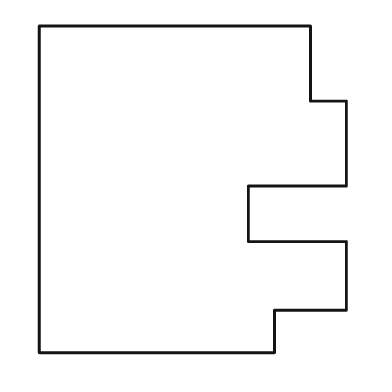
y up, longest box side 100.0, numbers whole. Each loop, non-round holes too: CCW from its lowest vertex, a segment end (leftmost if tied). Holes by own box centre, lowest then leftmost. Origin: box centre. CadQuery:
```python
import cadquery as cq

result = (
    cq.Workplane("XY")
    .moveTo(-47.0, -50.0)
    .lineTo(25.0, -50.0)
    .lineTo(25.0, -37.0)
    .lineTo(47.0, -37.0)
    .lineTo(47.0, -16.0)
    .lineTo(17.0, -16.0)
    .lineTo(17.0, 1.0)
    .lineTo(47.0, 1.0)
    .lineTo(47.0, 27.0)
    .lineTo(36.0, 27.0)
    .lineTo(36.0, 50.0)
    .lineTo(-47.0, 50.0)
    .close()
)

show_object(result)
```